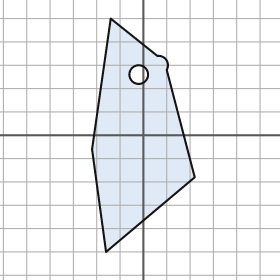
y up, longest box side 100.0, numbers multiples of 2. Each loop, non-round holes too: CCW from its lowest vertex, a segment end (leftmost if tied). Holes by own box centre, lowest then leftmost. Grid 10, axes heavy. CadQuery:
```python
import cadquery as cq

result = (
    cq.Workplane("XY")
    .moveTo(-16.0, -50.0)
    .lineTo(22.0, -18.0)
    .lineTo(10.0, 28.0)
    .threePointArc((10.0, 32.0), (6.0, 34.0))
    .lineTo(-14.0, 50.0)
    .lineTo(-22.0, -6.0)
    .close()
    .moveTo(-2.0, 26.0)
    .circle(4.0)
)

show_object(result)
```